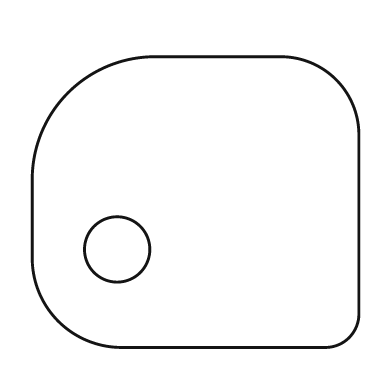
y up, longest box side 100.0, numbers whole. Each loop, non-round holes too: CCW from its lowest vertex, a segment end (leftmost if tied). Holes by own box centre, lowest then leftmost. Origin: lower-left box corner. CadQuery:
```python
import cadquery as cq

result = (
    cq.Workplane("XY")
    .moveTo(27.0, 0.0)
    .lineTo(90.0, 0.0)
    .threePointArc((97.0, 3.0), (100.0, 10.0))
    .lineTo(100.0, 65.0)
    .threePointArc((93.0, 82.0), (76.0, 89.0))
    .lineTo(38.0, 89.0)
    .threePointArc((11.0, 78.0), (0.0, 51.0))
    .lineTo(0.0, 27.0)
    .threePointArc((8.0, 8.0), (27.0, 0.0))
    .close()
    .moveTo(26.0, 30.0)
    .circle(10.0)
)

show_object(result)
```